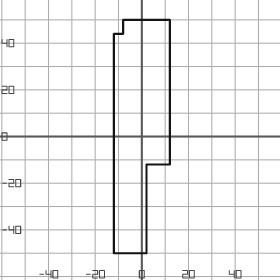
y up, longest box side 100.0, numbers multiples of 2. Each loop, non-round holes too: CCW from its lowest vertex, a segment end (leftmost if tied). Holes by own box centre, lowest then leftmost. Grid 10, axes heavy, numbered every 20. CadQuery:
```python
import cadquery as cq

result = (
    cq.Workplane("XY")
    .moveTo(-12.0, -50.0)
    .lineTo(2.0, -50.0)
    .lineTo(2.0, -12.0)
    .lineTo(12.0, -12.0)
    .lineTo(12.0, 50.0)
    .lineTo(-8.0, 50.0)
    .lineTo(-8.0, 44.0)
    .lineTo(-12.0, 44.0)
    .close()
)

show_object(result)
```